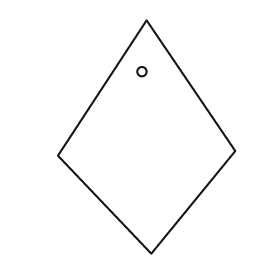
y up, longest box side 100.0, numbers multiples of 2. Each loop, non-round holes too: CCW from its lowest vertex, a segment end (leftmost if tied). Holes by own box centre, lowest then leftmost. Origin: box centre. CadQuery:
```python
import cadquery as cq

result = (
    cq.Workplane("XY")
    .moveTo(2.0, -50.0)
    .lineTo(38.0, -6.0)
    .lineTo(0.0, 50.0)
    .lineTo(-38.0, -8.0)
    .close()
    .moveTo(-2.0, 28.0)
    .circle(2.0)
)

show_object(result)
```